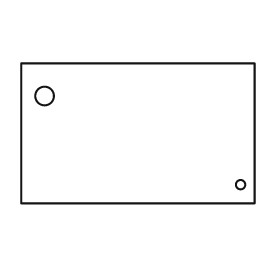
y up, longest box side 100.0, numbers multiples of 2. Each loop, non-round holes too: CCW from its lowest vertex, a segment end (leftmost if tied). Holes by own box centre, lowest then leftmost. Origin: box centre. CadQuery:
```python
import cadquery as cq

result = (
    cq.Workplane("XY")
    .moveTo(-50.0, -30.0)
    .lineTo(50.0, -30.0)
    .lineTo(50.0, 30.0)
    .lineTo(-50.0, 30.0)
    .close()
    .moveTo(44.0, -22.0)
    .circle(2.0)
    .moveTo(-40.0, 16.0)
    .circle(4.0)
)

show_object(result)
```